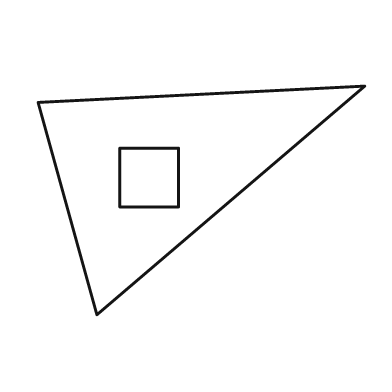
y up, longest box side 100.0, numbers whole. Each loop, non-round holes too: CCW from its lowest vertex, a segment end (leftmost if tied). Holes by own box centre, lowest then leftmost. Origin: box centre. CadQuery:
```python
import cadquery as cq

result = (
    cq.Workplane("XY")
    .moveTo(-32.0, -35.0)
    .lineTo(50.0, 35.0)
    .lineTo(-50.0, 30.0)
    .close()
    .moveTo(-25.0, -2.0)
    .lineTo(-7.0, -2.0)
    .lineTo(-7.0, 16.0)
    .lineTo(-25.0, 16.0)
    .close()
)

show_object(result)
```